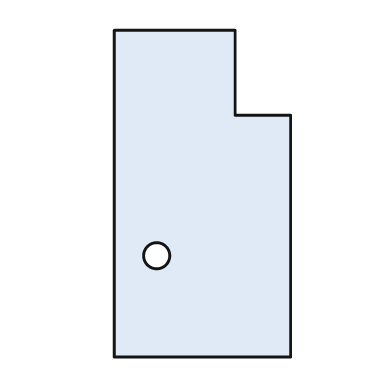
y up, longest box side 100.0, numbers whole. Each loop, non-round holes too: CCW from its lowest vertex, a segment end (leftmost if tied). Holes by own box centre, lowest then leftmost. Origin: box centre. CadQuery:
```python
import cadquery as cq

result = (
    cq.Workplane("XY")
    .moveTo(-27.0, -50.0)
    .lineTo(27.0, -50.0)
    .lineTo(27.0, 24.0)
    .lineTo(10.0, 24.0)
    .lineTo(10.0, 50.0)
    .lineTo(-27.0, 50.0)
    .close()
    .moveTo(-14.0, -19.0)
    .circle(4.0)
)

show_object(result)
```